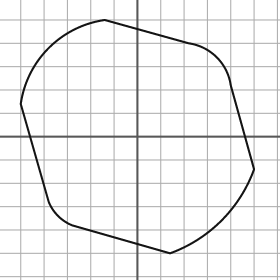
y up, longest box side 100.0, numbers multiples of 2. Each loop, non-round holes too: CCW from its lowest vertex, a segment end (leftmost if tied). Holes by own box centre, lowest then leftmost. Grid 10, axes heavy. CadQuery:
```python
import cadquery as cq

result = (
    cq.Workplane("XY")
    .moveTo(14.0, -50.0)
    .threePointArc((36.0, -36.0), (50.0, -14.0))
    .lineTo(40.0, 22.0)
    .threePointArc((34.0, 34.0), (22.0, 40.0))
    .lineTo(-14.0, 50.0)
    .threePointArc((-38.0, 38.0), (-50.0, 14.0))
    .lineTo(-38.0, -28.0)
    .threePointArc((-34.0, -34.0), (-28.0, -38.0))
    .close()
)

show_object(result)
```